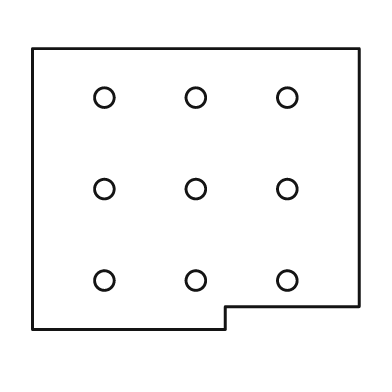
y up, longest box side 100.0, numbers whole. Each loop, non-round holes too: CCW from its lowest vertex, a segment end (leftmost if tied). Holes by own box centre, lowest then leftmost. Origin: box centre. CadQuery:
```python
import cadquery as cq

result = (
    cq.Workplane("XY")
    .moveTo(-50.0, -43.0)
    .lineTo(9.0, -43.0)
    .lineTo(9.0, -36.0)
    .lineTo(50.0, -36.0)
    .lineTo(50.0, 43.0)
    .lineTo(-50.0, 43.0)
    .close()
    .moveTo(-28.0, -28.0)
    .circle(3.0)
    .moveTo(0.0, -28.0)
    .circle(3.0)
    .moveTo(28.0, -28.0)
    .circle(3.0)
    .moveTo(-28.0, 0.0)
    .circle(3.0)
    .moveTo(0.0, 0.0)
    .circle(3.0)
    .moveTo(28.0, 0.0)
    .circle(3.0)
    .moveTo(-28.0, 28.0)
    .circle(3.0)
    .moveTo(0.0, 28.0)
    .circle(3.0)
    .moveTo(28.0, 28.0)
    .circle(3.0)
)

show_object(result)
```